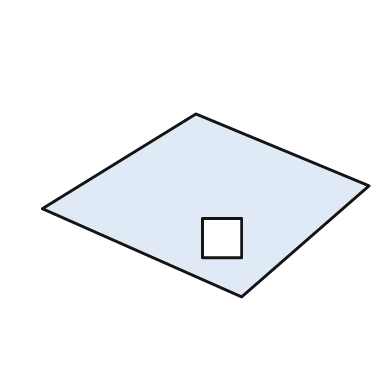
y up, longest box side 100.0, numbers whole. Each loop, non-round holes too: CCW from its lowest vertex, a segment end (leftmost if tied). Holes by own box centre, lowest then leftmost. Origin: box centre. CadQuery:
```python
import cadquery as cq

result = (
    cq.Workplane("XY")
    .moveTo(11.0, -28.0)
    .lineTo(50.0, 6.0)
    .lineTo(-3.0, 28.0)
    .lineTo(-50.0, -1.0)
    .close()
    .moveTo(-1.0, -16.0)
    .lineTo(11.0, -16.0)
    .lineTo(11.0, -4.0)
    .lineTo(-1.0, -4.0)
    .close()
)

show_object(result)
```